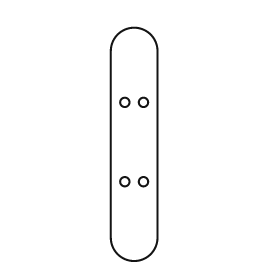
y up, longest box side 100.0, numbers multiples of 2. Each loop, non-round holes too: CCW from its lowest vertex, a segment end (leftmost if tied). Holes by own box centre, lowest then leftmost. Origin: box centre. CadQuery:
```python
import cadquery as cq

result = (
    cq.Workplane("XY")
    .moveTo(-10.0, -40.0)
    .threePointArc((0.0, -50.0), (10.0, -40.0))
    .lineTo(10.0, 40.0)
    .threePointArc((0.0, 50.0), (-10.0, 40.0))
    .close()
    .moveTo(-4.0, -16.0)
    .circle(2.0)
    .moveTo(4.0, -16.0)
    .circle(2.0)
    .moveTo(-4.0, 18.0)
    .circle(2.0)
    .moveTo(4.0, 18.0)
    .circle(2.0)
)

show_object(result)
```